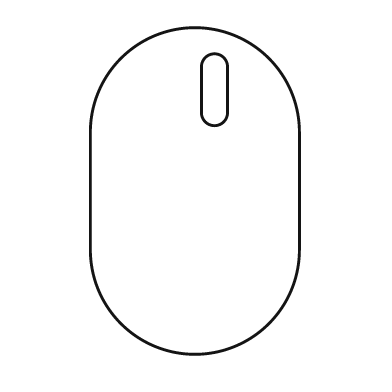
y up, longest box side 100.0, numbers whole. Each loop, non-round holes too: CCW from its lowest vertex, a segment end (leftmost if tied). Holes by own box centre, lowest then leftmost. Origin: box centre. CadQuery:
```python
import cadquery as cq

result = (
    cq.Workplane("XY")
    .moveTo(-32.0, -18.0)
    .threePointArc((0.0, -50.0), (32.0, -18.0))
    .lineTo(32.0, 18.0)
    .threePointArc((0.0, 50.0), (-32.0, 18.0))
    .close()
    .moveTo(2.0, 24.0)
    .threePointArc((6.0, 20.0), (10.0, 24.0))
    .lineTo(10.0, 38.0)
    .threePointArc((6.0, 42.0), (2.0, 38.0))
    .close()
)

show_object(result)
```